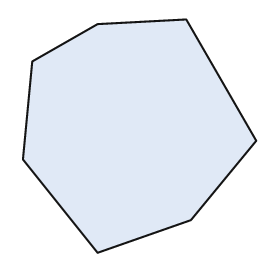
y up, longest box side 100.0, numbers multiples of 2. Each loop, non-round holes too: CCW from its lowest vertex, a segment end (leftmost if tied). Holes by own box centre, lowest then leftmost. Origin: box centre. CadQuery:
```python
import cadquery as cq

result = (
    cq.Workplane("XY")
    .moveTo(-18.0, -50.0)
    .lineTo(22.0, -36.0)
    .lineTo(50.0, -2.0)
    .lineTo(20.0, 50.0)
    .lineTo(-18.0, 48.0)
    .lineTo(-46.0, 32.0)
    .lineTo(-50.0, -10.0)
    .close()
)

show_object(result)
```